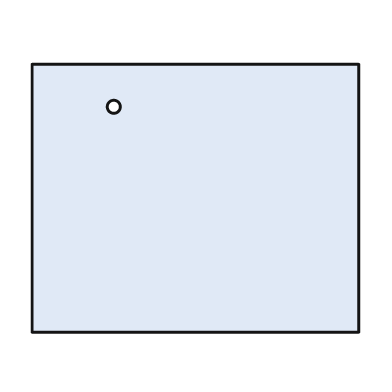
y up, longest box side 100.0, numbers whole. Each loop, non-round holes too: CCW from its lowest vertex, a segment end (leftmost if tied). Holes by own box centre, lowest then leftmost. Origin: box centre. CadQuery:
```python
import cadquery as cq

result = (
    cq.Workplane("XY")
    .moveTo(-50.0, -41.0)
    .lineTo(50.0, -41.0)
    .lineTo(50.0, 41.0)
    .lineTo(-50.0, 41.0)
    .close()
    .moveTo(-25.0, 28.0)
    .circle(2.0)
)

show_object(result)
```